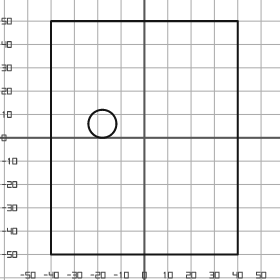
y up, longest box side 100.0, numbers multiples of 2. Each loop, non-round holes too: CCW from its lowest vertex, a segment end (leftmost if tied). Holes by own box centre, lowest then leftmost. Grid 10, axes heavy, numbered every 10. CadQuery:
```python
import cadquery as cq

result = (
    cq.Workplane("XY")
    .moveTo(-40.0, -50.0)
    .lineTo(40.0, -50.0)
    .lineTo(40.0, 50.0)
    .lineTo(-40.0, 50.0)
    .close()
    .moveTo(-18.0, 6.0)
    .circle(6.0)
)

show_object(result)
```